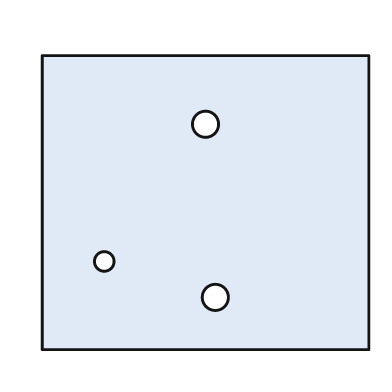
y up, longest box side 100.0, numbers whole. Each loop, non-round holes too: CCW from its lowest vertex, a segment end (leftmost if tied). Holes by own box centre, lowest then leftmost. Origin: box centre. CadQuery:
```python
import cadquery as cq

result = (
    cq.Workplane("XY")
    .moveTo(-50.0, -45.0)
    .lineTo(50.0, -45.0)
    .lineTo(50.0, 45.0)
    .lineTo(-50.0, 45.0)
    .close()
    .moveTo(3.0, -29.0)
    .circle(4.0)
    .moveTo(-31.0, -18.0)
    .circle(3.0)
    .moveTo(0.0, 24.0)
    .circle(4.0)
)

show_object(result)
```